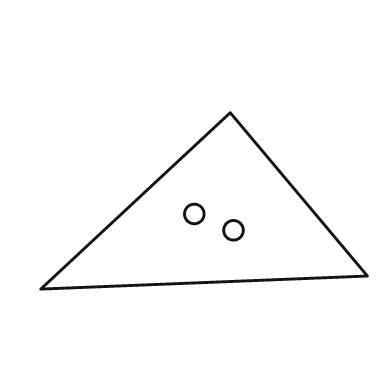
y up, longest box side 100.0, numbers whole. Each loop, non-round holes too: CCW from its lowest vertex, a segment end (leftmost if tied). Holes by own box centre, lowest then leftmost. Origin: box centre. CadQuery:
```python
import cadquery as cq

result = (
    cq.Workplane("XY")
    .moveTo(-50.0, -27.0)
    .lineTo(50.0, -23.0)
    .lineTo(8.0, 27.0)
    .close()
    .moveTo(9.0, -9.0)
    .circle(3.0)
    .moveTo(-3.0, -4.0)
    .circle(3.0)
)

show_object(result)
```